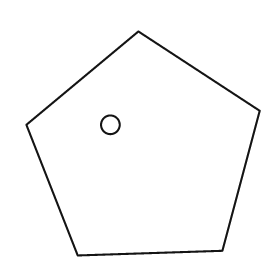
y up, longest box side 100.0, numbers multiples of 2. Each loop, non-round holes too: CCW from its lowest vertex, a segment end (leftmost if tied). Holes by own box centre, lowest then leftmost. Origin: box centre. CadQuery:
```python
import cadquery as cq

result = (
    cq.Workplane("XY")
    .moveTo(-28.0, -48.0)
    .lineTo(34.0, -46.0)
    .lineTo(50.0, 14.0)
    .lineTo(-2.0, 48.0)
    .lineTo(-50.0, 8.0)
    .close()
    .moveTo(-14.0, 8.0)
    .circle(4.0)
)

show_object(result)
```